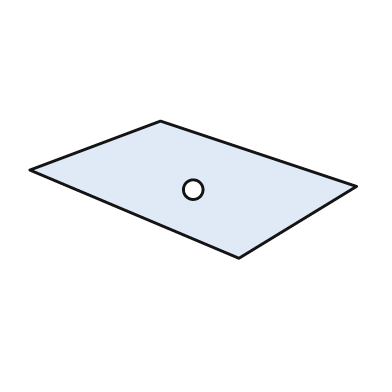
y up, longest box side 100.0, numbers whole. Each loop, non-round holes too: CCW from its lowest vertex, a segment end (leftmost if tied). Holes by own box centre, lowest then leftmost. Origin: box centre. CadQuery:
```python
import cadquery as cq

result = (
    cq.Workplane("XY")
    .moveTo(14.0, -21.0)
    .lineTo(50.0, 1.0)
    .lineTo(-10.0, 21.0)
    .lineTo(-50.0, 6.0)
    .close()
    .moveTo(0.0, 0.0)
    .circle(3.0)
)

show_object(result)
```